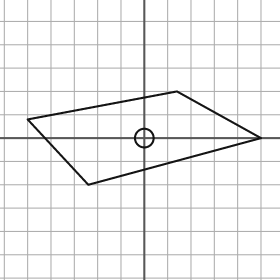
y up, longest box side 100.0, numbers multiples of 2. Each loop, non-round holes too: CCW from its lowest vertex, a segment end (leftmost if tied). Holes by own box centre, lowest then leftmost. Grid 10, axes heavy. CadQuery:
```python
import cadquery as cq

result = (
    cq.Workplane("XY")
    .moveTo(-24.0, -20.0)
    .lineTo(50.0, 0.0)
    .lineTo(14.0, 20.0)
    .lineTo(-50.0, 8.0)
    .close()
    .moveTo(0.0, 0.0)
    .circle(4.0)
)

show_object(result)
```